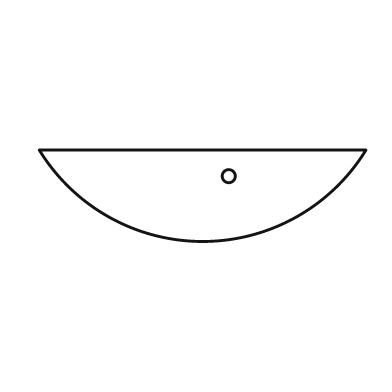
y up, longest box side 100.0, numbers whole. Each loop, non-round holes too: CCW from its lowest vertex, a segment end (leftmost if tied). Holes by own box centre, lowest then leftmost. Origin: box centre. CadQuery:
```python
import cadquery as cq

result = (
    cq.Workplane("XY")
    .moveTo(-50.0, 14.0)
    .threePointArc((0.0, -14.0), (50.0, 14.0))
    .close()
    .moveTo(8.0, 6.0)
    .circle(2.0)
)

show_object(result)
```